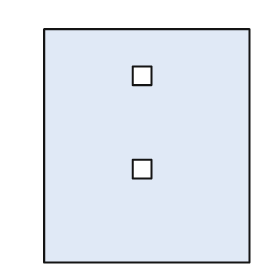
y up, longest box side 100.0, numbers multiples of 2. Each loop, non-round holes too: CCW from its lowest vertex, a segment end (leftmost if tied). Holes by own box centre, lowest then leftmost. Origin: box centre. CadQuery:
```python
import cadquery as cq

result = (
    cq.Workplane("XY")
    .moveTo(-44.0, -50.0)
    .lineTo(44.0, -50.0)
    .lineTo(44.0, 50.0)
    .lineTo(-44.0, 50.0)
    .close()
    .moveTo(-6.0, -14.0)
    .lineTo(2.0, -14.0)
    .lineTo(2.0, -6.0)
    .lineTo(-6.0, -6.0)
    .close()
    .moveTo(-6.0, 26.0)
    .lineTo(2.0, 26.0)
    .lineTo(2.0, 34.0)
    .lineTo(-6.0, 34.0)
    .close()
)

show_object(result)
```